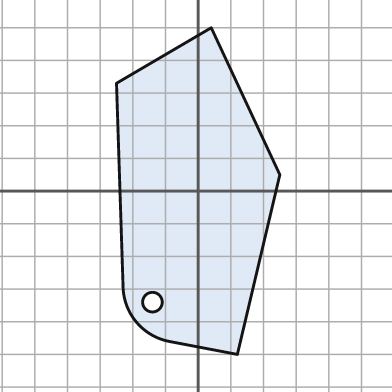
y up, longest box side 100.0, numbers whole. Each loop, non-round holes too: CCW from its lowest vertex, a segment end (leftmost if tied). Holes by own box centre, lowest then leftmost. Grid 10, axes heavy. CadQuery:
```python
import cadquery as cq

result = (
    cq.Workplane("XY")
    .moveTo(12.0, -50.0)
    .lineTo(25.0, 5.0)
    .lineTo(4.0, 50.0)
    .lineTo(-25.0, 33.0)
    .lineTo(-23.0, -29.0)
    .threePointArc((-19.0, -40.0), (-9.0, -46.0))
    .close()
    .moveTo(-14.0, -34.0)
    .circle(3.0)
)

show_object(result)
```